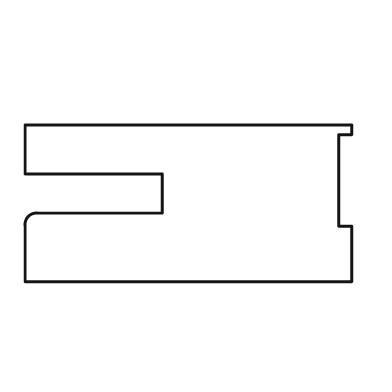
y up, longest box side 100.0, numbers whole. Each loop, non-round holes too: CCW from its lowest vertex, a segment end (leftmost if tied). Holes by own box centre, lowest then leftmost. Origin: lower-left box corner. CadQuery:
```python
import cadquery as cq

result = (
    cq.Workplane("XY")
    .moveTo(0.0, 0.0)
    .lineTo(100.0, 0.0)
    .lineTo(100.0, 17.0)
    .lineTo(96.0, 17.0)
    .lineTo(96.0, 45.0)
    .lineTo(100.0, 45.0)
    .lineTo(100.0, 48.0)
    .lineTo(0.0, 48.0)
    .lineTo(0.0, 33.0)
    .lineTo(42.0, 33.0)
    .lineTo(42.0, 21.0)
    .lineTo(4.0, 21.0)
    .threePointArc((1.0, 20.0), (0.0, 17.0))
    .close()
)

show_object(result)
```